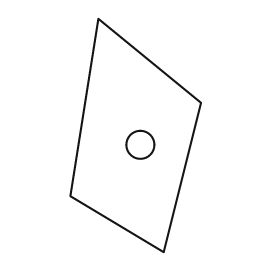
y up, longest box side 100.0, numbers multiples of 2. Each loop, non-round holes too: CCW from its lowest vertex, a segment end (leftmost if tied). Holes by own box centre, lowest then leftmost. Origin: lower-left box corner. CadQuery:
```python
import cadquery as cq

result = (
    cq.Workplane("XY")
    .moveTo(40.0, 0.0)
    .lineTo(56.0, 64.0)
    .lineTo(12.0, 100.0)
    .lineTo(0.0, 24.0)
    .close()
    .moveTo(30.0, 46.0)
    .circle(6.0)
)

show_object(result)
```